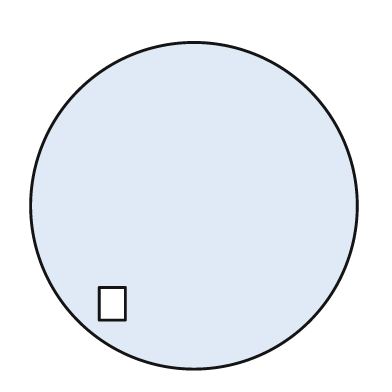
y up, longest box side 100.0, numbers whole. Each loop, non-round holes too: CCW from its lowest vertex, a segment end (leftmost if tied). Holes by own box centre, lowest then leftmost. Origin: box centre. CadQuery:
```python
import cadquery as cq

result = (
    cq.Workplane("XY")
    .moveTo(0.0, 0.0)
    .circle(50.0)
    .moveTo(-29.0, -35.0)
    .lineTo(-21.0, -35.0)
    .lineTo(-21.0, -25.0)
    .lineTo(-29.0, -25.0)
    .close()
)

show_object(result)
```